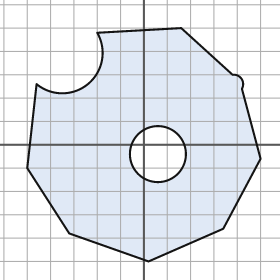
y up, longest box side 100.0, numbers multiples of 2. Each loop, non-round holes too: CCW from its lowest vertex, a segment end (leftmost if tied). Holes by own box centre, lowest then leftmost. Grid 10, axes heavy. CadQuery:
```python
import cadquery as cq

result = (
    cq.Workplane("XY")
    .moveTo(2.0, -50.0)
    .lineTo(34.0, -36.0)
    .lineTo(50.0, -6.0)
    .lineTo(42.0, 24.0)
    .threePointArc((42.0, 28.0), (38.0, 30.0))
    .lineTo(16.0, 50.0)
    .lineTo(-20.0, 48.0)
    .threePointArc((-24.0, 26.0), (-46.0, 26.0))
    .lineTo(-50.0, -10.0)
    .lineTo(-32.0, -38.0)
    .close()
    .moveTo(6.0, -4.0)
    .circle(12.0)
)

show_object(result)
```